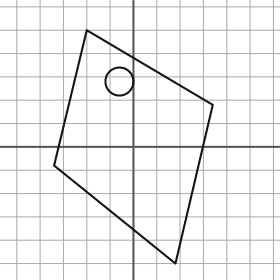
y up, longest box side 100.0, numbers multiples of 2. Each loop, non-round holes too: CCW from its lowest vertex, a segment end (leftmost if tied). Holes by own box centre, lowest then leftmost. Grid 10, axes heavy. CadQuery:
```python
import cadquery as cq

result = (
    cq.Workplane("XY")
    .moveTo(18.0, -50.0)
    .lineTo(34.0, 18.0)
    .lineTo(-20.0, 50.0)
    .lineTo(-34.0, -8.0)
    .close()
    .moveTo(-6.0, 28.0)
    .circle(6.0)
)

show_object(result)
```